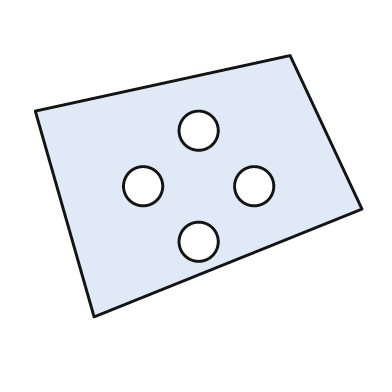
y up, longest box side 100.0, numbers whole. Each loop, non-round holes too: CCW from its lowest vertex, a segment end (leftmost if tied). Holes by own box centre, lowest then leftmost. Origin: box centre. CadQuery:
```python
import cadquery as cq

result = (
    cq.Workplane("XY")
    .moveTo(-32.0, -40.0)
    .lineTo(50.0, -7.0)
    .lineTo(28.0, 40.0)
    .lineTo(-50.0, 23.0)
    .close()
    .moveTo(0.0, -17.0)
    .circle(6.0)
    .moveTo(-17.0, 0.0)
    .circle(6.0)
    .moveTo(17.0, 0.0)
    .circle(6.0)
    .moveTo(0.0, 17.0)
    .circle(6.0)
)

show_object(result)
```